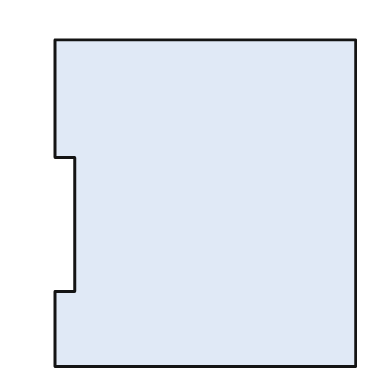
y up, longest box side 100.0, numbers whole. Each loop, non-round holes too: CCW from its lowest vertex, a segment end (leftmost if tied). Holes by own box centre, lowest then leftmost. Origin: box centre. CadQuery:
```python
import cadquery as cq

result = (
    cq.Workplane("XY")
    .moveTo(-46.0, -50.0)
    .lineTo(46.0, -50.0)
    .lineTo(46.0, 50.0)
    .lineTo(-46.0, 50.0)
    .lineTo(-46.0, 14.0)
    .lineTo(-40.0, 14.0)
    .lineTo(-40.0, -27.0)
    .lineTo(-46.0, -27.0)
    .close()
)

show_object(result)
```